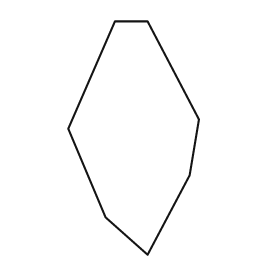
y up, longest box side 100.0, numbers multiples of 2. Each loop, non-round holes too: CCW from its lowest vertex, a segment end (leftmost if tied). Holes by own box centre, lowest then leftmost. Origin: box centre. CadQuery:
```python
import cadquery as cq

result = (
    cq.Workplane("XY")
    .moveTo(6.0, -50.0)
    .lineTo(24.0, -16.0)
    .lineTo(28.0, 8.0)
    .lineTo(6.0, 50.0)
    .lineTo(-8.0, 50.0)
    .lineTo(-28.0, 4.0)
    .lineTo(-12.0, -34.0)
    .close()
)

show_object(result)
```